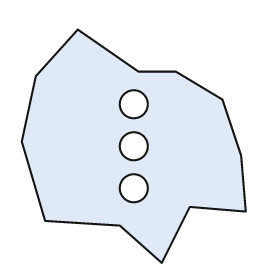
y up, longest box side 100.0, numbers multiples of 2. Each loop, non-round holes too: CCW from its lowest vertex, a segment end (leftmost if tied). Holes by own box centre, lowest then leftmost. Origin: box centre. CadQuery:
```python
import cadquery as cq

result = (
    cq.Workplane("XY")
    .moveTo(12.0, -50.0)
    .lineTo(24.0, -26.0)
    .lineTo(48.0, -28.0)
    .lineTo(46.0, -4.0)
    .lineTo(38.0, 20.0)
    .lineTo(18.0, 32.0)
    .lineTo(2.0, 32.0)
    .lineTo(-24.0, 50.0)
    .lineTo(-42.0, 30.0)
    .lineTo(-48.0, 2.0)
    .lineTo(-38.0, -32.0)
    .lineTo(-6.0, -34.0)
    .close()
    .moveTo(0.0, -18.0)
    .circle(6.0)
    .moveTo(0.0, 0.0)
    .circle(6.0)
    .moveTo(0.0, 18.0)
    .circle(6.0)
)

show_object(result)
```